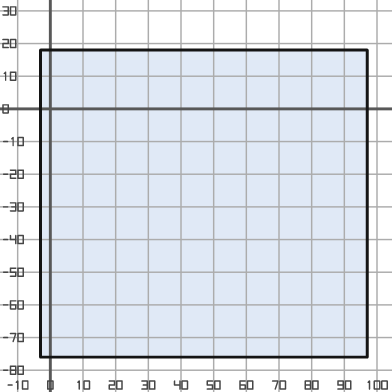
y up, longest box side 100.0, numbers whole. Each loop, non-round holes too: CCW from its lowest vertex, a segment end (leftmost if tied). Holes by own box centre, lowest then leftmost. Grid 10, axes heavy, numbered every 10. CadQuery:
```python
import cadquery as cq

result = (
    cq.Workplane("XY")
    .moveTo(-3.0, -76.0)
    .lineTo(97.0, -76.0)
    .lineTo(97.0, 18.0)
    .lineTo(-3.0, 18.0)
    .close()
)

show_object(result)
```